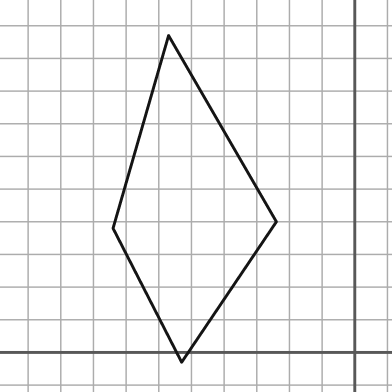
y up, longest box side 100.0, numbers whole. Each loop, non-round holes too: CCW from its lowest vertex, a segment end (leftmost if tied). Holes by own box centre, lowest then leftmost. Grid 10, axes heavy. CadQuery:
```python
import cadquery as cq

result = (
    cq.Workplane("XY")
    .moveTo(-53.0, -3.0)
    .lineTo(-24.0, 40.0)
    .lineTo(-57.0, 97.0)
    .lineTo(-74.0, 38.0)
    .close()
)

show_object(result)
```